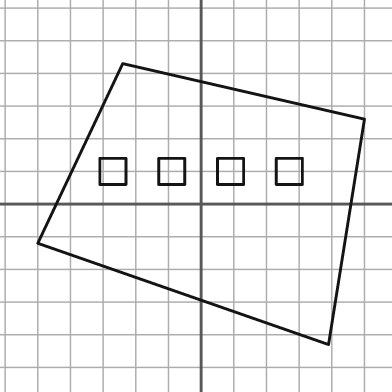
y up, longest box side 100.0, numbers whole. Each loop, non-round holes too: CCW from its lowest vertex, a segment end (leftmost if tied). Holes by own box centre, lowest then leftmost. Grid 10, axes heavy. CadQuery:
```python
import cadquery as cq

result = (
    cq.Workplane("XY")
    .moveTo(39.0, -43.0)
    .lineTo(50.0, 26.0)
    .lineTo(-24.0, 43.0)
    .lineTo(-50.0, -12.0)
    .close()
    .moveTo(-31.0, 6.0)
    .lineTo(-23.0, 6.0)
    .lineTo(-23.0, 14.0)
    .lineTo(-31.0, 14.0)
    .close()
    .moveTo(-13.0, 6.0)
    .lineTo(-5.0, 6.0)
    .lineTo(-5.0, 14.0)
    .lineTo(-13.0, 14.0)
    .close()
    .moveTo(5.0, 6.0)
    .lineTo(13.0, 6.0)
    .lineTo(13.0, 14.0)
    .lineTo(5.0, 14.0)
    .close()
    .moveTo(23.0, 6.0)
    .lineTo(31.0, 6.0)
    .lineTo(31.0, 14.0)
    .lineTo(23.0, 14.0)
    .close()
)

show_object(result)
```